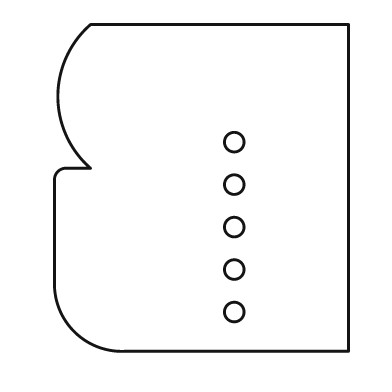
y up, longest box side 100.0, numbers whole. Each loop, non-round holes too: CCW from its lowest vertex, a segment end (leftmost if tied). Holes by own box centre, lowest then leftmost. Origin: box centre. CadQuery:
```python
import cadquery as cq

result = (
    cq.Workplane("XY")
    .moveTo(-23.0, -50.0)
    .lineTo(45.0, -50.0)
    .lineTo(45.0, 50.0)
    .lineTo(-34.0, 50.0)
    .threePointArc((-44.0, 28.0), (-34.0, 6.0))
    .lineTo(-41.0, 6.0)
    .threePointArc((-44.0, 5.0), (-45.0, 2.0))
    .lineTo(-45.0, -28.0)
    .threePointArc((-39.0, -44.0), (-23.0, -50.0))
    .close()
    .moveTo(10.0, -38.0)
    .circle(3.0)
    .moveTo(10.0, -25.0)
    .circle(3.0)
    .moveTo(10.0, -12.0)
    .circle(3.0)
    .moveTo(10.0, 1.0)
    .circle(3.0)
    .moveTo(10.0, 14.0)
    .circle(3.0)
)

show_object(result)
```